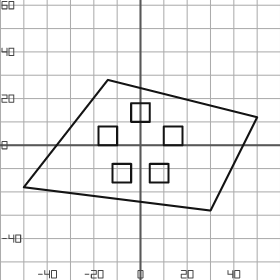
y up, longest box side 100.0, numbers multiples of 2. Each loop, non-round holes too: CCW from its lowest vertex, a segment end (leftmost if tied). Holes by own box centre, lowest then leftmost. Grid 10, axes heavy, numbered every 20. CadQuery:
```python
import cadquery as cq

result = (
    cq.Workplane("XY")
    .moveTo(30.0, -28.0)
    .lineTo(50.0, 12.0)
    .lineTo(-14.0, 28.0)
    .lineTo(-50.0, -18.0)
    .close()
    .moveTo(-12.0, -16.0)
    .lineTo(-4.0, -16.0)
    .lineTo(-4.0, -8.0)
    .lineTo(-12.0, -8.0)
    .close()
    .moveTo(4.0, -16.0)
    .lineTo(12.0, -16.0)
    .lineTo(12.0, -8.0)
    .lineTo(4.0, -8.0)
    .close()
    .moveTo(-18.0, 0.0)
    .lineTo(-10.0, 0.0)
    .lineTo(-10.0, 8.0)
    .lineTo(-18.0, 8.0)
    .close()
    .moveTo(10.0, 0.0)
    .lineTo(18.0, 0.0)
    .lineTo(18.0, 8.0)
    .lineTo(10.0, 8.0)
    .close()
    .moveTo(-4.0, 10.0)
    .lineTo(4.0, 10.0)
    .lineTo(4.0, 18.0)
    .lineTo(-4.0, 18.0)
    .close()
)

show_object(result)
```